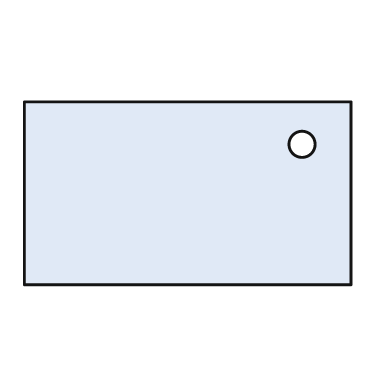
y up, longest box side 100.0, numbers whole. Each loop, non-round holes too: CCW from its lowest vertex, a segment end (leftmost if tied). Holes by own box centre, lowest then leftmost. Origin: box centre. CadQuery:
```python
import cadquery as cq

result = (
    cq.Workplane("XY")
    .moveTo(-50.0, -28.0)
    .lineTo(50.0, -28.0)
    .lineTo(50.0, 28.0)
    .lineTo(-50.0, 28.0)
    .close()
    .moveTo(35.0, 15.0)
    .circle(4.0)
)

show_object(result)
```